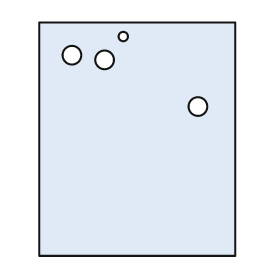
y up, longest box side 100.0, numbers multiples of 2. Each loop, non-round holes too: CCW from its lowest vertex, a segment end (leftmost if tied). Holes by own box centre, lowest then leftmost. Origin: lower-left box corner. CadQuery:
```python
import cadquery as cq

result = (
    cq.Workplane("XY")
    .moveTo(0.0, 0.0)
    .lineTo(84.0, 0.0)
    .lineTo(84.0, 100.0)
    .lineTo(0.0, 100.0)
    .close()
    .moveTo(68.0, 64.0)
    .circle(4.0)
    .moveTo(28.0, 84.0)
    .circle(4.0)
    .moveTo(14.0, 86.0)
    .circle(4.0)
    .moveTo(36.0, 94.0)
    .circle(2.0)
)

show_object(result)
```